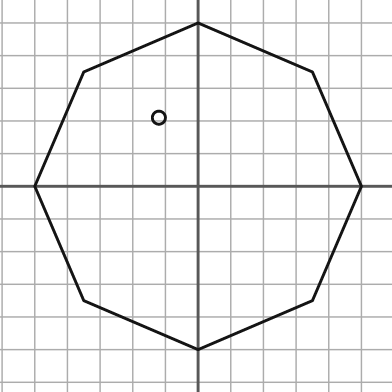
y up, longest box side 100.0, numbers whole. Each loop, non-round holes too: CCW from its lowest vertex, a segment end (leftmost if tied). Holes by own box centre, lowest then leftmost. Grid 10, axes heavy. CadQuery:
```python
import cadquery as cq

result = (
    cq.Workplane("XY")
    .moveTo(0.0, -50.0)
    .lineTo(35.0, -35.0)
    .lineTo(50.0, 0.0)
    .lineTo(35.0, 35.0)
    .lineTo(0.0, 50.0)
    .lineTo(-35.0, 35.0)
    .lineTo(-50.0, 0.0)
    .lineTo(-35.0, -35.0)
    .close()
    .moveTo(-12.0, 21.0)
    .circle(2.0)
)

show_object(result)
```